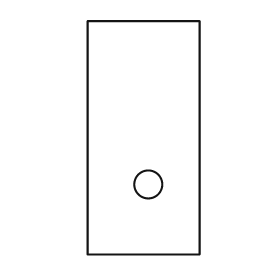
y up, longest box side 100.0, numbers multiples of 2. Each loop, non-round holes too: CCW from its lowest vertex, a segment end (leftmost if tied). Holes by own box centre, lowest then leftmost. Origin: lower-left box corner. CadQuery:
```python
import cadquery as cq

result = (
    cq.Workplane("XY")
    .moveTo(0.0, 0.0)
    .lineTo(48.0, 0.0)
    .lineTo(48.0, 100.0)
    .lineTo(0.0, 100.0)
    .close()
    .moveTo(26.0, 30.0)
    .circle(6.0)
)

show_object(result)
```